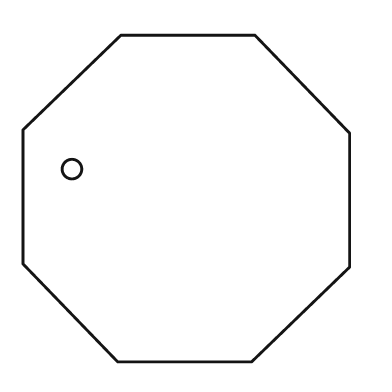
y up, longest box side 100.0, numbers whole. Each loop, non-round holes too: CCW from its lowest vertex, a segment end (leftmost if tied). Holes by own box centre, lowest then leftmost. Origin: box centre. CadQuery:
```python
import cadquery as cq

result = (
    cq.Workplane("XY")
    .moveTo(-21.0, -50.0)
    .lineTo(20.0, -50.0)
    .lineTo(50.0, -21.0)
    .lineTo(50.0, 20.0)
    .lineTo(21.0, 50.0)
    .lineTo(-20.0, 50.0)
    .lineTo(-50.0, 21.0)
    .lineTo(-50.0, -20.0)
    .close()
    .moveTo(-35.0, 9.0)
    .circle(3.0)
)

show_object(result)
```